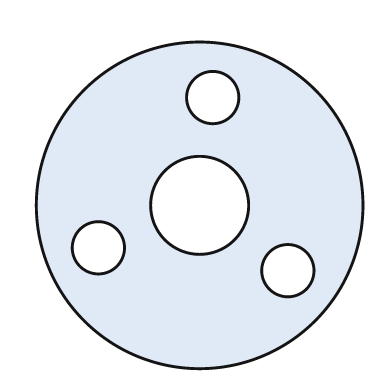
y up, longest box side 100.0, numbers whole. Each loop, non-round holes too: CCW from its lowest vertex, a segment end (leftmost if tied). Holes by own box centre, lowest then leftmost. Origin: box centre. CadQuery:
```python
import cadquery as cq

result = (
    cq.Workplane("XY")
    .moveTo(0.0, 0.0)
    .circle(50.0)
    .moveTo(27.0, -20.0)
    .circle(8.0)
    .moveTo(-31.0, -13.0)
    .circle(8.0)
    .moveTo(0.0, 0.0)
    .circle(15.0)
    .moveTo(4.0, 33.0)
    .circle(8.0)
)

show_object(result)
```